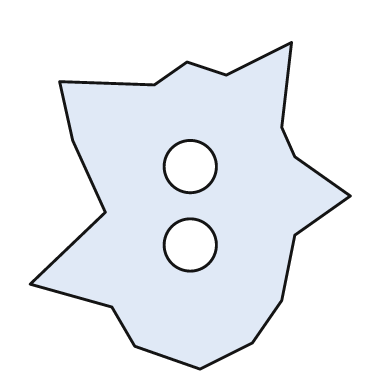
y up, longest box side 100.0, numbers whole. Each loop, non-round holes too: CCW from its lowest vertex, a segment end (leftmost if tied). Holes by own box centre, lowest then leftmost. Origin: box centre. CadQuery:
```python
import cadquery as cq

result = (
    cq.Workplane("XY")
    .moveTo(3.0, -50.0)
    .lineTo(19.0, -42.0)
    .lineTo(28.0, -29.0)
    .lineTo(32.0, -9.0)
    .lineTo(49.0, 3.0)
    .lineTo(32.0, 15.0)
    .lineTo(28.0, 24.0)
    .lineTo(31.0, 50.0)
    .lineTo(11.0, 40.0)
    .lineTo(-1.0, 44.0)
    .lineTo(-11.0, 37.0)
    .lineTo(-40.0, 38.0)
    .lineTo(-36.0, 20.0)
    .lineTo(-26.0, -2.0)
    .lineTo(-49.0, -24.0)
    .lineTo(-24.0, -31.0)
    .lineTo(-17.0, -43.0)
    .close()
    .moveTo(0.0, -12.0)
    .circle(8.0)
    .moveTo(0.0, 12.0)
    .circle(8.0)
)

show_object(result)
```